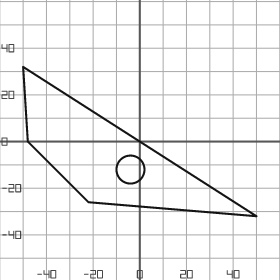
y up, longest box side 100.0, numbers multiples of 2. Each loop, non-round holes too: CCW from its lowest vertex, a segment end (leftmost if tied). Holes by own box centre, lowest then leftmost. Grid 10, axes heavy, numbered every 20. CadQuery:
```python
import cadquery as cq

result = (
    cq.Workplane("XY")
    .moveTo(50.0, -32.0)
    .lineTo(-50.0, 32.0)
    .lineTo(-48.0, 0.0)
    .lineTo(-22.0, -26.0)
    .close()
    .moveTo(-4.0, -12.0)
    .circle(6.0)
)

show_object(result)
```